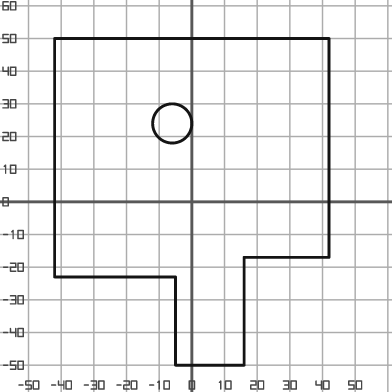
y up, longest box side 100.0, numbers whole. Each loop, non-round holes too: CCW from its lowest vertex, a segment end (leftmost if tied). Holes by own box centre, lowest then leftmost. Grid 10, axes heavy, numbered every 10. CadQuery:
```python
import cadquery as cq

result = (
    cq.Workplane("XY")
    .moveTo(-5.0, -50.0)
    .lineTo(16.0, -50.0)
    .lineTo(16.0, -17.0)
    .lineTo(42.0, -17.0)
    .lineTo(42.0, 50.0)
    .lineTo(-42.0, 50.0)
    .lineTo(-42.0, -23.0)
    .lineTo(-5.0, -23.0)
    .close()
    .moveTo(-6.0, 24.0)
    .circle(6.0)
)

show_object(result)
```